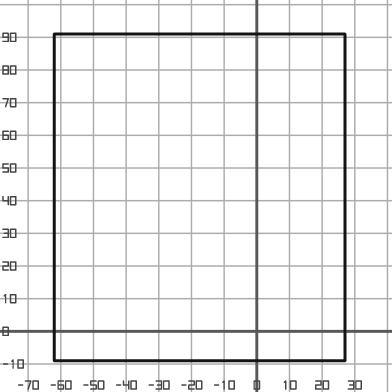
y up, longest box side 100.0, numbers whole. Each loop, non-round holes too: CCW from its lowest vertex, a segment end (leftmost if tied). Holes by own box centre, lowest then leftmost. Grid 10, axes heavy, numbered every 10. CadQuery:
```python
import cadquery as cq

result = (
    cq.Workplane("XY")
    .moveTo(-62.0, -9.0)
    .lineTo(27.0, -9.0)
    .lineTo(27.0, 91.0)
    .lineTo(-62.0, 91.0)
    .close()
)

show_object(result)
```